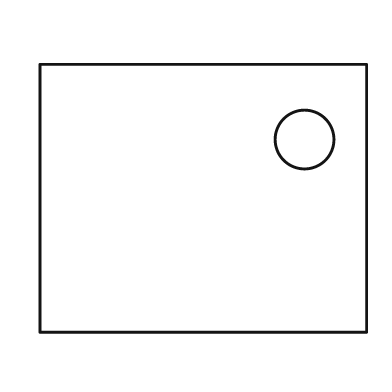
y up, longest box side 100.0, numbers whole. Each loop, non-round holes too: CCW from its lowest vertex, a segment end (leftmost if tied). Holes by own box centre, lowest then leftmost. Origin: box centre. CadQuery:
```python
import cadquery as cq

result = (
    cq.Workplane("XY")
    .moveTo(-50.0, -41.0)
    .lineTo(50.0, -41.0)
    .lineTo(50.0, 41.0)
    .lineTo(-50.0, 41.0)
    .close()
    .moveTo(31.0, 18.0)
    .circle(9.0)
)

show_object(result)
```